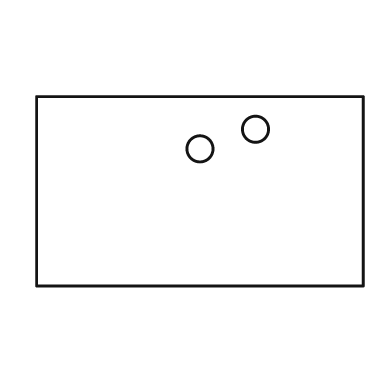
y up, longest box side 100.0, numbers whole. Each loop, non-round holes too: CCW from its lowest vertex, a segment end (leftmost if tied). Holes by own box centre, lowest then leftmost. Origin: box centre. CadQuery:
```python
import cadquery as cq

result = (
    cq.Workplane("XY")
    .moveTo(-50.0, -29.0)
    .lineTo(50.0, -29.0)
    .lineTo(50.0, 29.0)
    .lineTo(-50.0, 29.0)
    .close()
    .moveTo(0.0, 13.0)
    .circle(4.0)
    .moveTo(17.0, 19.0)
    .circle(4.0)
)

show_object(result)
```